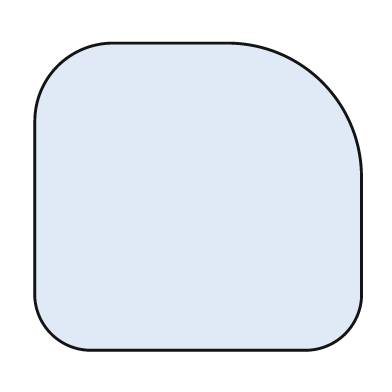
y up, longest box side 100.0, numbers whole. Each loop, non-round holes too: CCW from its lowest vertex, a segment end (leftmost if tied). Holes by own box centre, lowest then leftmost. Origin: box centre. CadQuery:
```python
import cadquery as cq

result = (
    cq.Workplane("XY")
    .moveTo(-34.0, -47.0)
    .lineTo(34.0, -47.0)
    .threePointArc((45.0, -42.0), (50.0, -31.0))
    .lineTo(50.0, 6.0)
    .threePointArc((38.0, 35.0), (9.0, 47.0))
    .lineTo(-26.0, 47.0)
    .threePointArc((-43.0, 40.0), (-50.0, 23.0))
    .lineTo(-50.0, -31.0)
    .threePointArc((-45.0, -42.0), (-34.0, -47.0))
    .close()
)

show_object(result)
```